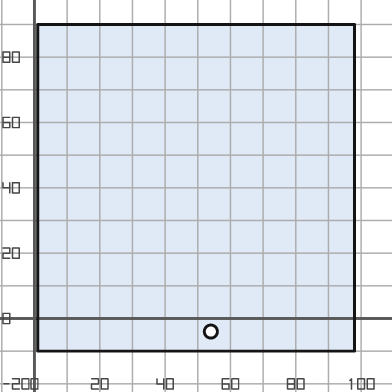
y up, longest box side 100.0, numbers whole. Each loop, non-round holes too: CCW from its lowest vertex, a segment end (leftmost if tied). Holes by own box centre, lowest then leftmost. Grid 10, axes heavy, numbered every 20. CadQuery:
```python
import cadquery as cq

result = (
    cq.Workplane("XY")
    .moveTo(1.0, -10.0)
    .lineTo(98.0, -10.0)
    .lineTo(98.0, 90.0)
    .lineTo(1.0, 90.0)
    .close()
    .moveTo(54.0, -4.0)
    .circle(2.0)
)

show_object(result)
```